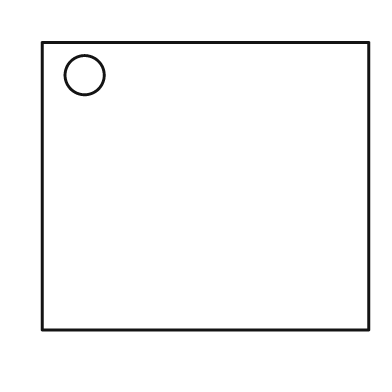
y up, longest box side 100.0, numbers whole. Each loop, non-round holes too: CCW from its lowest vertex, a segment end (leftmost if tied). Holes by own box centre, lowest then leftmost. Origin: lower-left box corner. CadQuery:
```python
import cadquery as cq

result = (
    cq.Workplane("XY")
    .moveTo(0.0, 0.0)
    .lineTo(100.0, 0.0)
    .lineTo(100.0, 88.0)
    .lineTo(0.0, 88.0)
    .close()
    .moveTo(13.0, 78.0)
    .circle(6.0)
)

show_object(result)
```